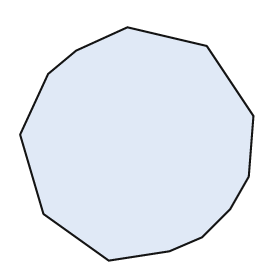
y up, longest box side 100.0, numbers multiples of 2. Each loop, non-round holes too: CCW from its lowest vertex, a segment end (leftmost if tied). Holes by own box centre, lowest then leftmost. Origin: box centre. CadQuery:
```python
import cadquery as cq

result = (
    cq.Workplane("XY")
    .moveTo(-12.0, -50.0)
    .lineTo(14.0, -46.0)
    .lineTo(28.0, -40.0)
    .lineTo(40.0, -28.0)
    .lineTo(48.0, -14.0)
    .lineTo(50.0, 12.0)
    .lineTo(30.0, 42.0)
    .lineTo(-4.0, 50.0)
    .lineTo(-26.0, 40.0)
    .lineTo(-38.0, 30.0)
    .lineTo(-50.0, 4.0)
    .lineTo(-40.0, -30.0)
    .close()
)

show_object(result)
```